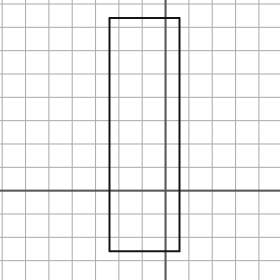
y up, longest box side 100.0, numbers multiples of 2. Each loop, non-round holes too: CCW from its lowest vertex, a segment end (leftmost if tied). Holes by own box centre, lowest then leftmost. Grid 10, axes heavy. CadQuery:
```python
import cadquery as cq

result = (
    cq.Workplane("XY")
    .moveTo(-24.0, -26.0)
    .lineTo(6.0, -26.0)
    .lineTo(6.0, 74.0)
    .lineTo(-24.0, 74.0)
    .close()
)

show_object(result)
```